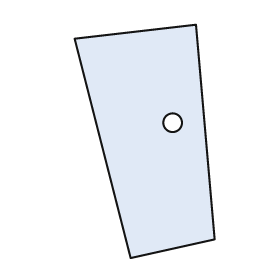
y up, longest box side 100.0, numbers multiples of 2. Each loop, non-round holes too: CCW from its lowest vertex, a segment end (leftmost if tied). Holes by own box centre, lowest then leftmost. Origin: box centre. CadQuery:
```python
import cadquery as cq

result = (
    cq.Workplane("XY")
    .moveTo(-6.0, -50.0)
    .lineTo(30.0, -42.0)
    .lineTo(22.0, 50.0)
    .lineTo(-30.0, 44.0)
    .close()
    .moveTo(12.0, 8.0)
    .circle(4.0)
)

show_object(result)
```